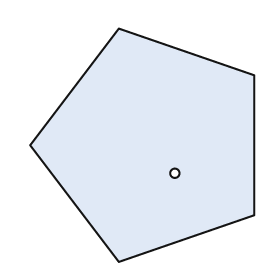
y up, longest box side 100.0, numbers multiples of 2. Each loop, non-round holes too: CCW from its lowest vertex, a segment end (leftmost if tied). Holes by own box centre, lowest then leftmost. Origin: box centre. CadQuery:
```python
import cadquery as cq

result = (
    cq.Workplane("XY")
    .moveTo(-10.0, -50.0)
    .lineTo(48.0, -30.0)
    .lineTo(48.0, 30.0)
    .lineTo(-10.0, 50.0)
    .lineTo(-48.0, 0.0)
    .close()
    .moveTo(14.0, -12.0)
    .circle(2.0)
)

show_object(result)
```